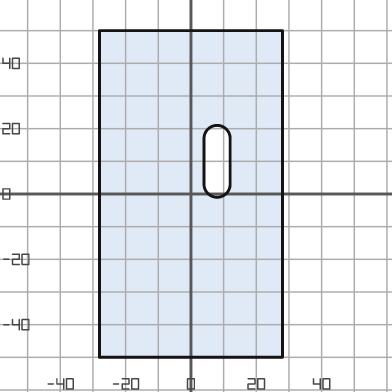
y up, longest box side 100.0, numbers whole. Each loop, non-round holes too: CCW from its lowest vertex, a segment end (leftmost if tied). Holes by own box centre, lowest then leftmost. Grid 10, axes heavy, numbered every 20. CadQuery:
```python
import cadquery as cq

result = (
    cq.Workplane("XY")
    .moveTo(-28.0, -50.0)
    .lineTo(28.0, -50.0)
    .lineTo(28.0, 50.0)
    .lineTo(-28.0, 50.0)
    .close()
    .moveTo(4.0, 3.0)
    .threePointArc((8.0, -1.0), (12.0, 3.0))
    .lineTo(12.0, 17.0)
    .threePointArc((8.0, 21.0), (4.0, 17.0))
    .close()
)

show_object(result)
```